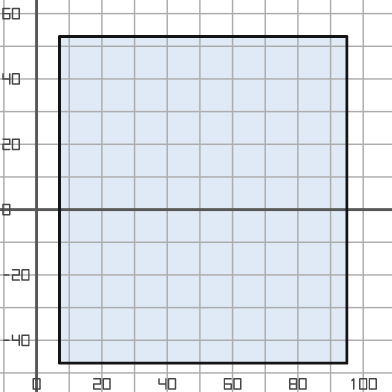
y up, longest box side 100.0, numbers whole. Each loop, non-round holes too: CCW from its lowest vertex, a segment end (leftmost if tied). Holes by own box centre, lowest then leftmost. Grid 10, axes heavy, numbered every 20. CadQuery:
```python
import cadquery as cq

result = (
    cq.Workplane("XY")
    .moveTo(7.0, -47.0)
    .lineTo(95.0, -47.0)
    .lineTo(95.0, 53.0)
    .lineTo(7.0, 53.0)
    .close()
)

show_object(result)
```